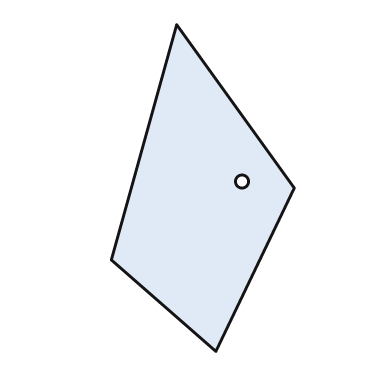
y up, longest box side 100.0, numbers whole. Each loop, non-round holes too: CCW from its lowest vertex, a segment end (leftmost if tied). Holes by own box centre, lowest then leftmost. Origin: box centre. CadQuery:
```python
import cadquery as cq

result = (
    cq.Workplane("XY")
    .moveTo(4.0, -50.0)
    .lineTo(28.0, 0.0)
    .lineTo(-8.0, 50.0)
    .lineTo(-28.0, -22.0)
    .close()
    .moveTo(12.0, 2.0)
    .circle(2.0)
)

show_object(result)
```